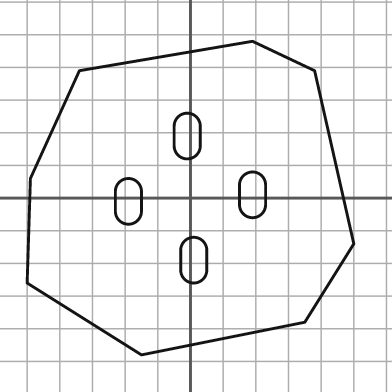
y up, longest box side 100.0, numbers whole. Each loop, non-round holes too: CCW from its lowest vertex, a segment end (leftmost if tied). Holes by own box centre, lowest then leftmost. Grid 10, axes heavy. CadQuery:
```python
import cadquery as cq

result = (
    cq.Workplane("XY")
    .moveTo(-15.0, -48.0)
    .lineTo(35.0, -38.0)
    .lineTo(50.0, -14.0)
    .lineTo(38.0, 39.0)
    .lineTo(19.0, 48.0)
    .lineTo(-34.0, 39.0)
    .lineTo(-49.0, 6.0)
    .lineTo(-50.0, -26.0)
    .close()
    .moveTo(-3.0, -22.0)
    .threePointArc((1.0, -26.0), (5.0, -22.0))
    .lineTo(5.0, -16.0)
    .threePointArc((1.0, -12.0), (-3.0, -16.0))
    .close()
    .moveTo(-23.0, -4.0)
    .threePointArc((-19.0, -8.0), (-15.0, -4.0))
    .lineTo(-15.0, 2.0)
    .threePointArc((-19.0, 6.0), (-23.0, 2.0))
    .close()
    .moveTo(15.0, -2.0)
    .threePointArc((19.0, -6.0), (23.0, -2.0))
    .lineTo(23.0, 4.0)
    .threePointArc((19.0, 8.0), (15.0, 4.0))
    .close()
    .moveTo(-5.0, 16.0)
    .threePointArc((-1.0, 12.0), (3.0, 16.0))
    .lineTo(3.0, 22.0)
    .threePointArc((-1.0, 26.0), (-5.0, 22.0))
    .close()
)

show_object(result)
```